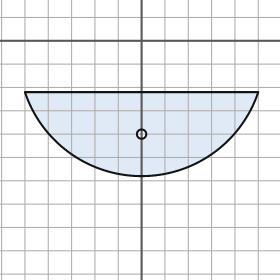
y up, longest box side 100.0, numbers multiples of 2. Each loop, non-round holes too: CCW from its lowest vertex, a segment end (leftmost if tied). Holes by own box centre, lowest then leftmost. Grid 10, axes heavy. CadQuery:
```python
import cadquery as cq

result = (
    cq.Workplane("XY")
    .moveTo(-50.0, -22.0)
    .threePointArc((0.0, -58.0), (50.0, -22.0))
    .close()
    .moveTo(0.0, -40.0)
    .circle(2.0)
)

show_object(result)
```